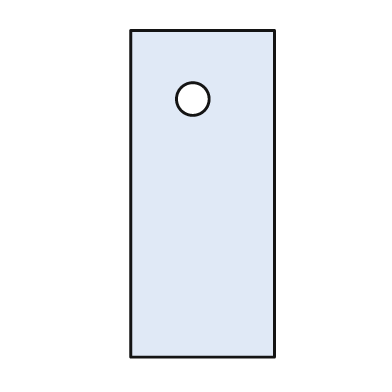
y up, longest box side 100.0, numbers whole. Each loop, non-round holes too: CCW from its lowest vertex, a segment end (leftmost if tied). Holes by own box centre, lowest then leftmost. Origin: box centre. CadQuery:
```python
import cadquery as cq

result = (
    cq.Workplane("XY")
    .moveTo(-22.0, -50.0)
    .lineTo(22.0, -50.0)
    .lineTo(22.0, 50.0)
    .lineTo(-22.0, 50.0)
    .close()
    .moveTo(-3.0, 29.0)
    .circle(5.0)
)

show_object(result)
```